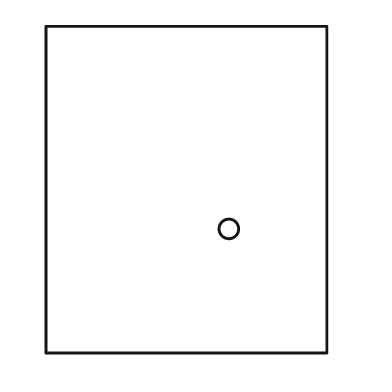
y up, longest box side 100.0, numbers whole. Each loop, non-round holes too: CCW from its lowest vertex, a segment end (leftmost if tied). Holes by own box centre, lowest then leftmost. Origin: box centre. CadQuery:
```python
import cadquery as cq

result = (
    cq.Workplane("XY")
    .moveTo(-43.0, -50.0)
    .lineTo(43.0, -50.0)
    .lineTo(43.0, 50.0)
    .lineTo(-43.0, 50.0)
    .close()
    .moveTo(13.0, -12.0)
    .circle(3.0)
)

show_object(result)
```